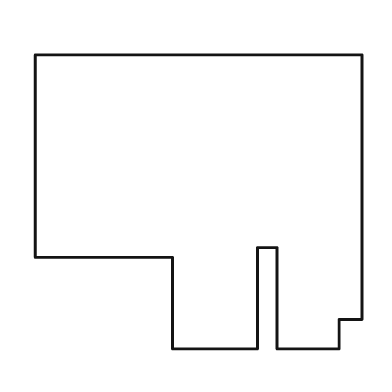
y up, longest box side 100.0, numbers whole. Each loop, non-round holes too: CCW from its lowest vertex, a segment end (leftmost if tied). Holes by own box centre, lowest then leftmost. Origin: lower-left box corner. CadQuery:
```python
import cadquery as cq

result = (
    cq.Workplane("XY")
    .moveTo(42.0, 0.0)
    .lineTo(68.0, 0.0)
    .lineTo(68.0, 31.0)
    .lineTo(74.0, 31.0)
    .lineTo(74.0, 0.0)
    .lineTo(93.0, 0.0)
    .lineTo(93.0, 9.0)
    .lineTo(100.0, 9.0)
    .lineTo(100.0, 90.0)
    .lineTo(0.0, 90.0)
    .lineTo(0.0, 28.0)
    .lineTo(42.0, 28.0)
    .close()
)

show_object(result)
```